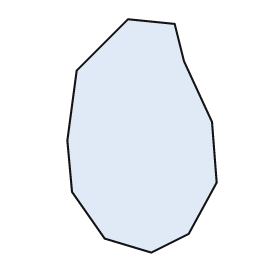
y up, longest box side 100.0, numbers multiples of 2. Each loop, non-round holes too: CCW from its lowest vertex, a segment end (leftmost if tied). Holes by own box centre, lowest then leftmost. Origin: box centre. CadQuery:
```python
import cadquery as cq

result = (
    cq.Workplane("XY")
    .moveTo(4.0, -50.0)
    .lineTo(20.0, -42.0)
    .lineTo(32.0, -20.0)
    .lineTo(30.0, 6.0)
    .lineTo(18.0, 32.0)
    .lineTo(14.0, 48.0)
    .lineTo(-6.0, 50.0)
    .lineTo(-28.0, 28.0)
    .lineTo(-32.0, -2.0)
    .lineTo(-30.0, -24.0)
    .lineTo(-16.0, -44.0)
    .close()
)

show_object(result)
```